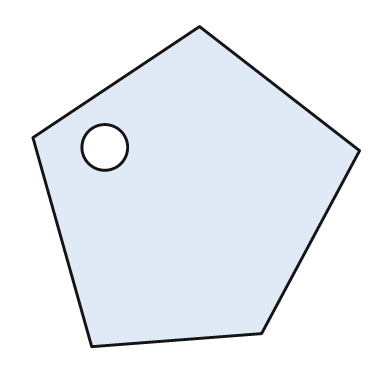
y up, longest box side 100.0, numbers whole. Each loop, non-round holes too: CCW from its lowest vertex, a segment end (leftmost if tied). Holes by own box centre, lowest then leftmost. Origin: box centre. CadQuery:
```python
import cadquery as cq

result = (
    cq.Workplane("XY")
    .moveTo(-32.0, -49.0)
    .lineTo(20.0, -45.0)
    .lineTo(50.0, 11.0)
    .lineTo(1.0, 49.0)
    .lineTo(-50.0, 15.0)
    .close()
    .moveTo(-28.0, 12.0)
    .circle(7.0)
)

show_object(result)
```